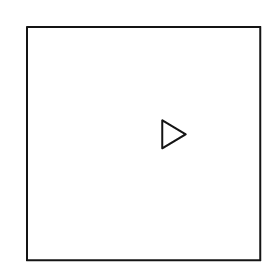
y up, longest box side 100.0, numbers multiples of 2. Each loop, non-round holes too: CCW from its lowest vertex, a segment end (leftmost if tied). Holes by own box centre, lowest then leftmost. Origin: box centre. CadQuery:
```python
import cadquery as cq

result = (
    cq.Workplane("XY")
    .moveTo(-50.0, -50.0)
    .lineTo(50.0, -50.0)
    .lineTo(50.0, 50.0)
    .lineTo(-50.0, 50.0)
    .close()
    .moveTo(8.0, -2.0)
    .lineTo(18.0, 4.0)
    .lineTo(8.0, 10.0)
    .close()
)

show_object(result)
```